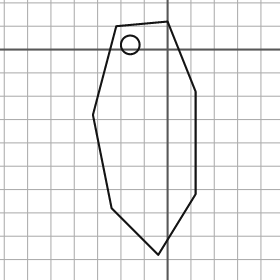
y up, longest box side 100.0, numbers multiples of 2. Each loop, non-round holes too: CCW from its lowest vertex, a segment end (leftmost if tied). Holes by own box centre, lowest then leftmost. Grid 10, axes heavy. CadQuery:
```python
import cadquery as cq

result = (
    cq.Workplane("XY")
    .moveTo(-4.0, -88.0)
    .lineTo(12.0, -62.0)
    .lineTo(12.0, -18.0)
    .lineTo(0.0, 12.0)
    .lineTo(-22.0, 10.0)
    .lineTo(-32.0, -28.0)
    .lineTo(-24.0, -68.0)
    .close()
    .moveTo(-16.0, 2.0)
    .circle(4.0)
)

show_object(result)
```